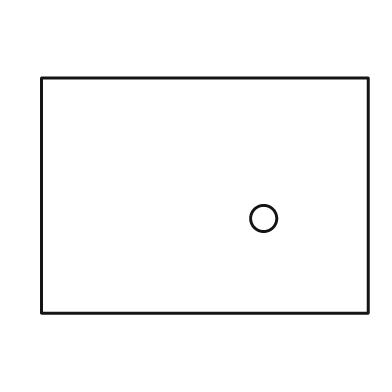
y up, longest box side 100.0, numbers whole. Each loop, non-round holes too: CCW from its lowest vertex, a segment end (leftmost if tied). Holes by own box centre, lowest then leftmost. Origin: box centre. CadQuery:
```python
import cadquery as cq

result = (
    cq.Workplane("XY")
    .moveTo(-50.0, -36.0)
    .lineTo(50.0, -36.0)
    .lineTo(50.0, 36.0)
    .lineTo(-50.0, 36.0)
    .close()
    .moveTo(18.0, -7.0)
    .circle(4.0)
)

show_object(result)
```